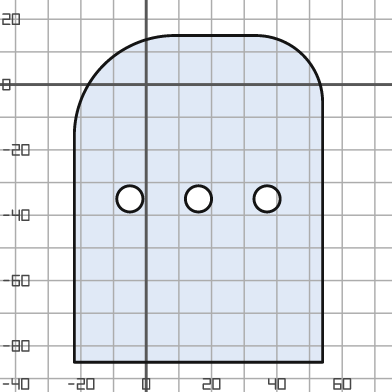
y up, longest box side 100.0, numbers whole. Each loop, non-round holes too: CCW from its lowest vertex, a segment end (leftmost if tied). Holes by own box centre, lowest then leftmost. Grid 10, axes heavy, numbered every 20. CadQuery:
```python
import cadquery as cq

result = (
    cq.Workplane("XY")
    .moveTo(-22.0, -85.0)
    .lineTo(54.0, -85.0)
    .lineTo(54.0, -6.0)
    .threePointArc((48.0, 9.0), (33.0, 15.0))
    .lineTo(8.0, 15.0)
    .threePointArc((-13.0, 6.0), (-22.0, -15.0))
    .close()
    .moveTo(-5.0, -35.0)
    .circle(4.0)
    .moveTo(16.0, -35.0)
    .circle(4.0)
    .moveTo(37.0, -35.0)
    .circle(4.0)
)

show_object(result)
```